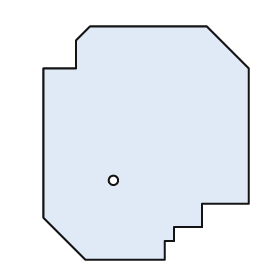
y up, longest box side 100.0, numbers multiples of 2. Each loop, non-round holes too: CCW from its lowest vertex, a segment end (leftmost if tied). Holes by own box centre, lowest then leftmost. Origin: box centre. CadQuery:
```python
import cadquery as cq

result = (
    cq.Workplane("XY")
    .moveTo(-26.0, -50.0)
    .lineTo(8.0, -50.0)
    .lineTo(8.0, -42.0)
    .lineTo(12.0, -42.0)
    .lineTo(12.0, -36.0)
    .lineTo(24.0, -36.0)
    .lineTo(24.0, -26.0)
    .lineTo(44.0, -26.0)
    .lineTo(44.0, 32.0)
    .lineTo(26.0, 50.0)
    .lineTo(-24.0, 50.0)
    .lineTo(-30.0, 44.0)
    .lineTo(-30.0, 32.0)
    .lineTo(-44.0, 32.0)
    .lineTo(-44.0, -32.0)
    .close()
    .moveTo(-14.0, -16.0)
    .circle(2.0)
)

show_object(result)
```